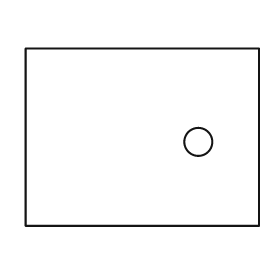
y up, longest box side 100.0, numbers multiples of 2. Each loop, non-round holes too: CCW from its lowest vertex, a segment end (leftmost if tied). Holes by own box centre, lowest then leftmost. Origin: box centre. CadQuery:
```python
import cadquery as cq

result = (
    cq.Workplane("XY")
    .moveTo(-50.0, -38.0)
    .lineTo(50.0, -38.0)
    .lineTo(50.0, 38.0)
    .lineTo(-50.0, 38.0)
    .close()
    .moveTo(24.0, -2.0)
    .circle(6.0)
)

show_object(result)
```